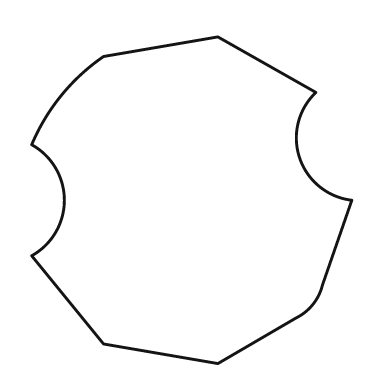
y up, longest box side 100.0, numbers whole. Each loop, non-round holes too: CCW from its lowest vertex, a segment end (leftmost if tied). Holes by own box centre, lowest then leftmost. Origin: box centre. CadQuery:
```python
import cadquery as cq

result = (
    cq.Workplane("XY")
    .moveTo(8.0, -50.0)
    .lineTo(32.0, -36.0)
    .threePointArc((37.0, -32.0), (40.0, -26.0))
    .lineTo(49.0, 0.0)
    .threePointArc((33.0, 13.0), (38.0, 33.0))
    .lineTo(8.0, 50.0)
    .lineTo(-27.0, 44.0)
    .threePointArc((-40.0, 32.0), (-49.0, 17.0))
    .threePointArc((-39.0, 0.0), (-49.0, -17.0))
    .lineTo(-27.0, -44.0)
    .close()
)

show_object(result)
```